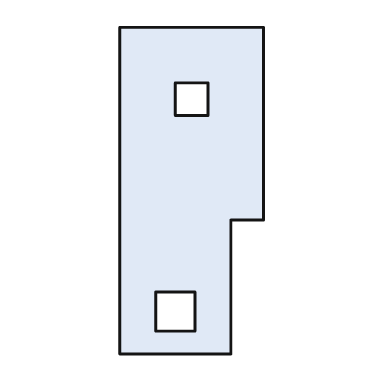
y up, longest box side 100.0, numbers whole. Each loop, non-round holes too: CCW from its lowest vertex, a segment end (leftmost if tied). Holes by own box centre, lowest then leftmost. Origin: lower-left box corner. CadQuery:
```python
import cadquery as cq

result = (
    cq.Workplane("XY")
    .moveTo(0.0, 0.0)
    .lineTo(34.0, 0.0)
    .lineTo(34.0, 41.0)
    .lineTo(44.0, 41.0)
    .lineTo(44.0, 100.0)
    .lineTo(0.0, 100.0)
    .close()
    .moveTo(11.0, 7.0)
    .lineTo(23.0, 7.0)
    .lineTo(23.0, 19.0)
    .lineTo(11.0, 19.0)
    .close()
    .moveTo(17.0, 73.0)
    .lineTo(27.0, 73.0)
    .lineTo(27.0, 83.0)
    .lineTo(17.0, 83.0)
    .close()
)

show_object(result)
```